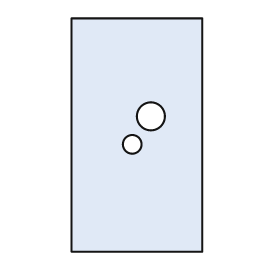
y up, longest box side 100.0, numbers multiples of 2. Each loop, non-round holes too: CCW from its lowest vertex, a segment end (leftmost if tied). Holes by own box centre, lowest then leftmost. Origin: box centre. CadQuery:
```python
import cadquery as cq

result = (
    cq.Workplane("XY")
    .moveTo(-28.0, -50.0)
    .lineTo(28.0, -50.0)
    .lineTo(28.0, 50.0)
    .lineTo(-28.0, 50.0)
    .close()
    .moveTo(-2.0, -4.0)
    .circle(4.0)
    .moveTo(6.0, 8.0)
    .circle(6.0)
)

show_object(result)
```